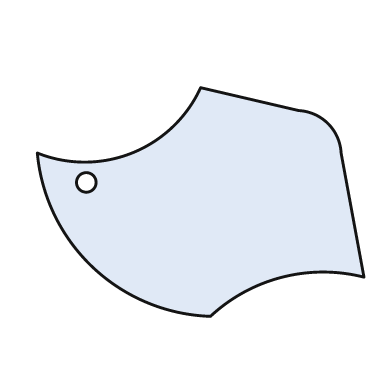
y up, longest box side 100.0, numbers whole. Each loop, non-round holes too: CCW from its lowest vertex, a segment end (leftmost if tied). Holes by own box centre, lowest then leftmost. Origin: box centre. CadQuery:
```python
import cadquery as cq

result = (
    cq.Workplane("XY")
    .moveTo(3.0, -35.0)
    .threePointArc((25.0, -23.0), (50.0, -23.0))
    .lineTo(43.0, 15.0)
    .threePointArc((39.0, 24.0), (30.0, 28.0))
    .lineTo(0.0, 35.0)
    .threePointArc((-21.0, 15.0), (-50.0, 15.0))
    .threePointArc((-33.0, -20.0), (3.0, -35.0))
    .close()
    .moveTo(-35.0, 6.0)
    .circle(3.0)
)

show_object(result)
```